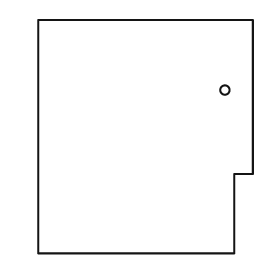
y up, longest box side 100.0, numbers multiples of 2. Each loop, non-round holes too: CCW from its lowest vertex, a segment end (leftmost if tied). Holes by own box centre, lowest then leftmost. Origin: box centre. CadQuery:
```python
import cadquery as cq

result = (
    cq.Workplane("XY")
    .moveTo(-46.0, -50.0)
    .lineTo(38.0, -50.0)
    .lineTo(38.0, -16.0)
    .lineTo(46.0, -16.0)
    .lineTo(46.0, 50.0)
    .lineTo(-46.0, 50.0)
    .close()
    .moveTo(34.0, 20.0)
    .circle(2.0)
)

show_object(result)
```